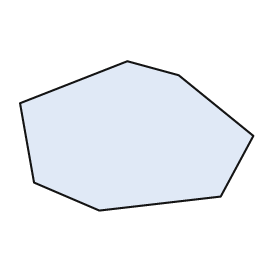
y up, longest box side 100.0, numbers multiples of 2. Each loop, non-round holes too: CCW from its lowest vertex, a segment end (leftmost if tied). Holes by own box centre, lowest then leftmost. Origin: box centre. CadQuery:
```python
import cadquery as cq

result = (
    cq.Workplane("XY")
    .moveTo(-16.0, -32.0)
    .lineTo(36.0, -26.0)
    .lineTo(50.0, 0.0)
    .lineTo(18.0, 26.0)
    .lineTo(-4.0, 32.0)
    .lineTo(-50.0, 14.0)
    .lineTo(-44.0, -20.0)
    .close()
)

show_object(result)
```